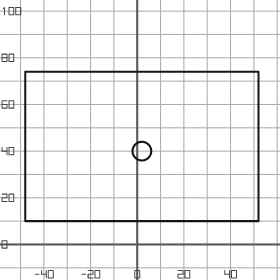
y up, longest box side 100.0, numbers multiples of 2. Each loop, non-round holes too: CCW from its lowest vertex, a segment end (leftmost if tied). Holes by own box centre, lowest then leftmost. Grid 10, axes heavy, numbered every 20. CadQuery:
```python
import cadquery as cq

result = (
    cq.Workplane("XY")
    .moveTo(-48.0, 10.0)
    .lineTo(52.0, 10.0)
    .lineTo(52.0, 74.0)
    .lineTo(-48.0, 74.0)
    .close()
    .moveTo(2.0, 40.0)
    .circle(4.0)
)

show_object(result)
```